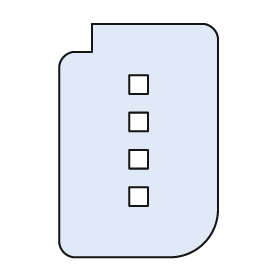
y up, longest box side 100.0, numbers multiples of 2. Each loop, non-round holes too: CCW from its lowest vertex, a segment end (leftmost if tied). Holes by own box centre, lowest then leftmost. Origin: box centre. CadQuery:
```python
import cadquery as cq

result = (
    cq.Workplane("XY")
    .moveTo(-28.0, -50.0)
    .lineTo(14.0, -50.0)
    .threePointArc((28.0, -44.0), (34.0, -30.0))
    .lineTo(34.0, 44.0)
    .threePointArc((32.0, 48.0), (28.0, 50.0))
    .lineTo(-20.0, 50.0)
    .lineTo(-20.0, 38.0)
    .lineTo(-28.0, 38.0)
    .threePointArc((-32.0, 36.0), (-34.0, 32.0))
    .lineTo(-34.0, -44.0)
    .threePointArc((-32.0, -48.0), (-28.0, -50.0))
    .close()
    .moveTo(-4.0, -28.0)
    .lineTo(4.0, -28.0)
    .lineTo(4.0, -20.0)
    .lineTo(-4.0, -20.0)
    .close()
    .moveTo(-4.0, -12.0)
    .lineTo(4.0, -12.0)
    .lineTo(4.0, -4.0)
    .lineTo(-4.0, -4.0)
    .close()
    .moveTo(-4.0, 4.0)
    .lineTo(4.0, 4.0)
    .lineTo(4.0, 12.0)
    .lineTo(-4.0, 12.0)
    .close()
    .moveTo(-4.0, 20.0)
    .lineTo(4.0, 20.0)
    .lineTo(4.0, 28.0)
    .lineTo(-4.0, 28.0)
    .close()
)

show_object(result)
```